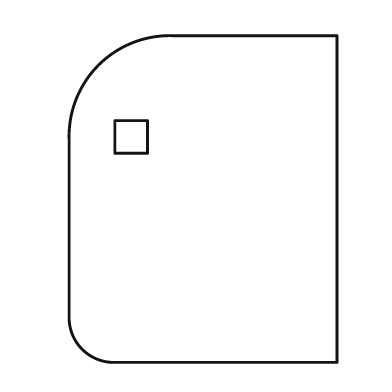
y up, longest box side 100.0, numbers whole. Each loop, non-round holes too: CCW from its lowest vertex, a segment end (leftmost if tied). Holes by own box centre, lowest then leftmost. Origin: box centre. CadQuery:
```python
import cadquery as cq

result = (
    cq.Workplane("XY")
    .moveTo(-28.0, -50.0)
    .lineTo(41.0, -50.0)
    .lineTo(41.0, 50.0)
    .lineTo(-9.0, 50.0)
    .threePointArc((-32.0, 41.0), (-41.0, 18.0))
    .lineTo(-41.0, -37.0)
    .threePointArc((-37.0, -46.0), (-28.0, -50.0))
    .close()
    .moveTo(-27.0, 14.0)
    .lineTo(-17.0, 14.0)
    .lineTo(-17.0, 24.0)
    .lineTo(-27.0, 24.0)
    .close()
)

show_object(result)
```